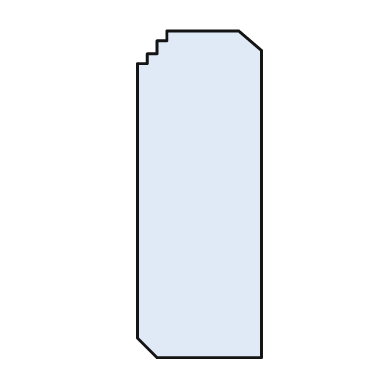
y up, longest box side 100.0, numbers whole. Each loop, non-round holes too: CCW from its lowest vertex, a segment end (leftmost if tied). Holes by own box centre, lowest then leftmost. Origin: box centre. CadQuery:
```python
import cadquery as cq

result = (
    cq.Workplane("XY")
    .moveTo(-13.0, -50.0)
    .lineTo(19.0, -50.0)
    .lineTo(19.0, 44.0)
    .lineTo(12.0, 50.0)
    .lineTo(-10.0, 50.0)
    .lineTo(-10.0, 47.0)
    .lineTo(-13.0, 47.0)
    .lineTo(-13.0, 43.0)
    .lineTo(-16.0, 43.0)
    .lineTo(-16.0, 40.0)
    .lineTo(-19.0, 40.0)
    .lineTo(-19.0, -44.0)
    .close()
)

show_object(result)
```